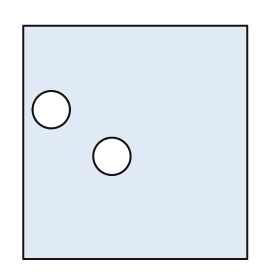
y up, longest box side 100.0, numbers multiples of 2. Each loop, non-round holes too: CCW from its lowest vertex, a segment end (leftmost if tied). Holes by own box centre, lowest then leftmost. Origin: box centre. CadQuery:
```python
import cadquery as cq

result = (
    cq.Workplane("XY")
    .moveTo(-48.0, -50.0)
    .lineTo(48.0, -50.0)
    .lineTo(48.0, 50.0)
    .lineTo(-48.0, 50.0)
    .close()
    .moveTo(-10.0, -6.0)
    .circle(8.0)
    .moveTo(-36.0, 14.0)
    .circle(8.0)
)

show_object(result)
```